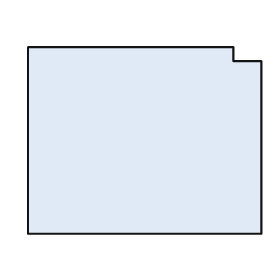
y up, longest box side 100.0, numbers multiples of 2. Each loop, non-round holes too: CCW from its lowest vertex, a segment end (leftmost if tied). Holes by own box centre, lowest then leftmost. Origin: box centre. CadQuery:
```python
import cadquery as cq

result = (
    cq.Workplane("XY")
    .moveTo(-50.0, -40.0)
    .lineTo(50.0, -40.0)
    .lineTo(50.0, 34.0)
    .lineTo(38.0, 34.0)
    .lineTo(38.0, 40.0)
    .lineTo(-50.0, 40.0)
    .close()
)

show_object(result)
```